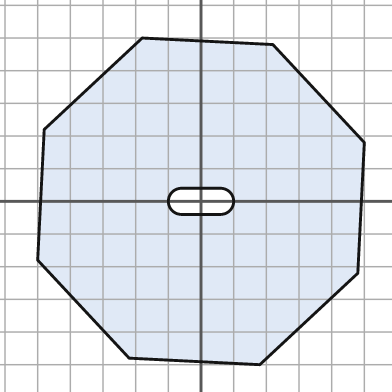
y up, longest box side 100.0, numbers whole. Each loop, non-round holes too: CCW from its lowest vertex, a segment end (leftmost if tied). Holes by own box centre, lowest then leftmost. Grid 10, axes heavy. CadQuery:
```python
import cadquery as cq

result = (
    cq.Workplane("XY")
    .moveTo(18.0, -50.0)
    .lineTo(48.0, -22.0)
    .lineTo(50.0, 18.0)
    .lineTo(22.0, 48.0)
    .lineTo(-18.0, 50.0)
    .lineTo(-48.0, 22.0)
    .lineTo(-50.0, -18.0)
    .lineTo(-22.0, -48.0)
    .close()
    .moveTo(-6.0, -4.0)
    .lineTo(6.0, -4.0)
    .threePointArc((10.0, 0.0), (6.0, 4.0))
    .lineTo(-6.0, 4.0)
    .threePointArc((-10.0, 0.0), (-6.0, -4.0))
    .close()
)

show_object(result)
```